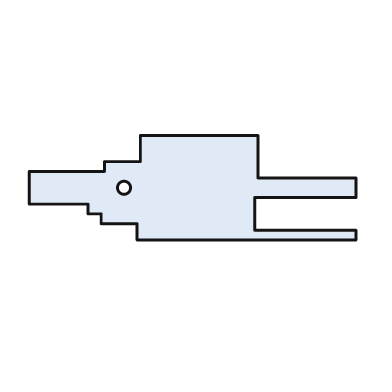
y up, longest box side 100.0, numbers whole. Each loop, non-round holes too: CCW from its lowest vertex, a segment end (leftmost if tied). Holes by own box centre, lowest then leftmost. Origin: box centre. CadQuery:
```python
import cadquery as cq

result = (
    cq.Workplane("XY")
    .moveTo(-17.0, -16.0)
    .lineTo(50.0, -16.0)
    .lineTo(50.0, -13.0)
    .lineTo(19.0, -13.0)
    .lineTo(19.0, -3.0)
    .lineTo(50.0, -3.0)
    .lineTo(50.0, 3.0)
    .lineTo(20.0, 3.0)
    .lineTo(20.0, 16.0)
    .lineTo(-16.0, 16.0)
    .lineTo(-16.0, 8.0)
    .lineTo(-27.0, 8.0)
    .lineTo(-27.0, 5.0)
    .lineTo(-50.0, 5.0)
    .lineTo(-50.0, -5.0)
    .lineTo(-32.0, -5.0)
    .lineTo(-32.0, -8.0)
    .lineTo(-28.0, -8.0)
    .lineTo(-28.0, -11.0)
    .lineTo(-17.0, -11.0)
    .close()
    .moveTo(-21.0, 0.0)
    .circle(2.0)
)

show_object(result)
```